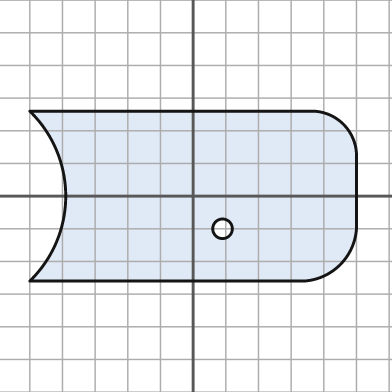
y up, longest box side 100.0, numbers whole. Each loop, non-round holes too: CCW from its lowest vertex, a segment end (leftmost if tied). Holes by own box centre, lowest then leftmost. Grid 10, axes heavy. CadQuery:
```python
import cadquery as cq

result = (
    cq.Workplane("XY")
    .moveTo(-50.0, -26.0)
    .lineTo(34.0, -26.0)
    .threePointArc((45.0, -21.0), (50.0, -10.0))
    .lineTo(50.0, 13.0)
    .threePointArc((46.0, 22.0), (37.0, 26.0))
    .lineTo(-50.0, 26.0)
    .threePointArc((-39.0, 0.0), (-50.0, -26.0))
    .close()
    .moveTo(9.0, -10.0)
    .circle(3.0)
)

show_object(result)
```